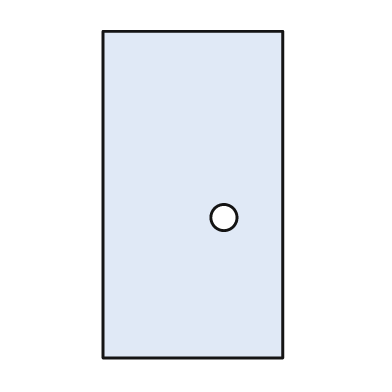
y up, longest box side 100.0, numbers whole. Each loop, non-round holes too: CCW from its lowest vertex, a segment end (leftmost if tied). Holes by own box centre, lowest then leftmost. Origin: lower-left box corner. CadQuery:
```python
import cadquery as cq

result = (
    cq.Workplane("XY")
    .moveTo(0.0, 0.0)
    .lineTo(55.0, 0.0)
    .lineTo(55.0, 100.0)
    .lineTo(0.0, 100.0)
    .close()
    .moveTo(37.0, 43.0)
    .circle(4.0)
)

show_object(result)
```